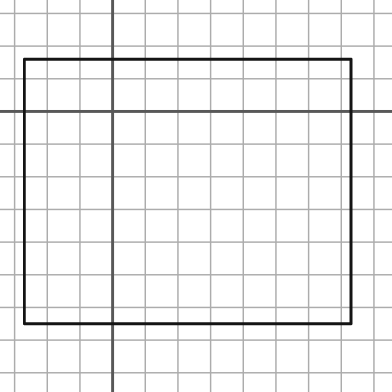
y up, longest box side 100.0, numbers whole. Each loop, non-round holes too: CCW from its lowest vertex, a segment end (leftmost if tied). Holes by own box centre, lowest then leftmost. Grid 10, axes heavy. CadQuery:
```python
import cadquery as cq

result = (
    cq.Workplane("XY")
    .moveTo(-27.0, -65.0)
    .lineTo(73.0, -65.0)
    .lineTo(73.0, 16.0)
    .lineTo(-27.0, 16.0)
    .close()
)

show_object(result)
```